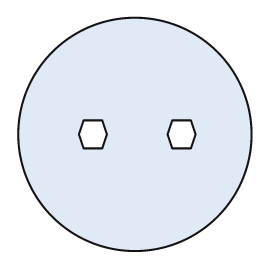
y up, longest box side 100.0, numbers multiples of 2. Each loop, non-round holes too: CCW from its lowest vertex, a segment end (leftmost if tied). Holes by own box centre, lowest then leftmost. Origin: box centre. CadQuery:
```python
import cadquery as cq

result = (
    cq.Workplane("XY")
    .moveTo(0.0, 0.0)
    .circle(50.0)
    .moveTo(-22.0, -6.0)
    .lineTo(-14.0, -6.0)
    .lineTo(-12.0, 0.0)
    .lineTo(-14.0, 6.0)
    .lineTo(-22.0, 6.0)
    .lineTo(-24.0, 0.0)
    .close()
    .moveTo(16.0, -6.0)
    .lineTo(24.0, -6.0)
    .lineTo(26.0, 0.0)
    .lineTo(24.0, 6.0)
    .lineTo(16.0, 6.0)
    .lineTo(14.0, 0.0)
    .close()
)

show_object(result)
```